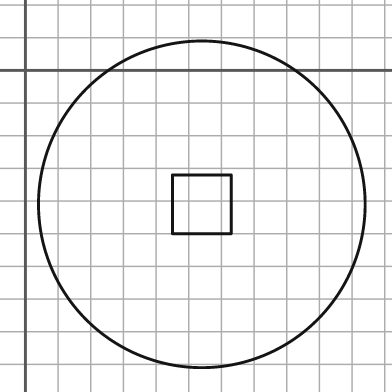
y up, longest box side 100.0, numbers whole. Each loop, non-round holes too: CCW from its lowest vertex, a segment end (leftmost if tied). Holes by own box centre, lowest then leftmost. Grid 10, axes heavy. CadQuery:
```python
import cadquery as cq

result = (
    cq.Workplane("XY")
    .moveTo(54.0, -41.0)
    .circle(50.0)
    .moveTo(45.0, -50.0)
    .lineTo(63.0, -50.0)
    .lineTo(63.0, -32.0)
    .lineTo(45.0, -32.0)
    .close()
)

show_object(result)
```